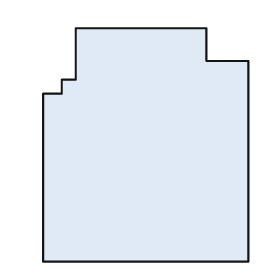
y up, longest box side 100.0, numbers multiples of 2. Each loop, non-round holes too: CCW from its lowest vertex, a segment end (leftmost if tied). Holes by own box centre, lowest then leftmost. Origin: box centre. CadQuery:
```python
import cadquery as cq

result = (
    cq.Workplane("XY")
    .moveTo(-44.0, -50.0)
    .lineTo(44.0, -50.0)
    .lineTo(44.0, 36.0)
    .lineTo(26.0, 36.0)
    .lineTo(26.0, 50.0)
    .lineTo(-30.0, 50.0)
    .lineTo(-30.0, 28.0)
    .lineTo(-36.0, 28.0)
    .lineTo(-36.0, 22.0)
    .lineTo(-44.0, 22.0)
    .close()
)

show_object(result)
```